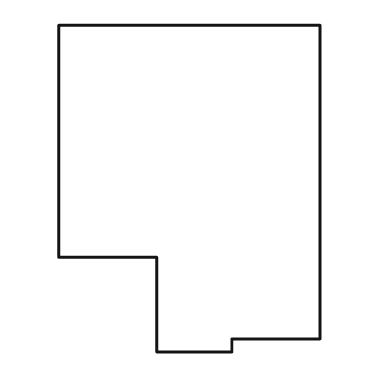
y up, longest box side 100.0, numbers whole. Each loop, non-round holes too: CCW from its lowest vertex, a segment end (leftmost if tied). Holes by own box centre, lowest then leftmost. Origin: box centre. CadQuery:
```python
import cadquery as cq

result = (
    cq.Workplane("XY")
    .moveTo(-10.0, -50.0)
    .lineTo(13.0, -50.0)
    .lineTo(13.0, -46.0)
    .lineTo(40.0, -46.0)
    .lineTo(40.0, 50.0)
    .lineTo(-40.0, 50.0)
    .lineTo(-40.0, -21.0)
    .lineTo(-10.0, -21.0)
    .close()
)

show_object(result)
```